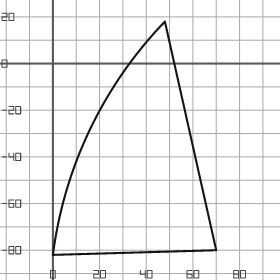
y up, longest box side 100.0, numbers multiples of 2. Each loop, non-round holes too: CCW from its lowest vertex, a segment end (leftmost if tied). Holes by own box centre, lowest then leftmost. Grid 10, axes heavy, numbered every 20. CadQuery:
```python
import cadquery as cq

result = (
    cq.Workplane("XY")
    .moveTo(0.0, -82.0)
    .lineTo(70.0, -80.0)
    .lineTo(48.0, 18.0)
    .threePointArc((16.0, -28.0), (0.0, -82.0))
    .close()
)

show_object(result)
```